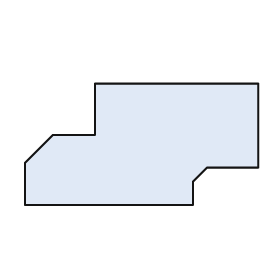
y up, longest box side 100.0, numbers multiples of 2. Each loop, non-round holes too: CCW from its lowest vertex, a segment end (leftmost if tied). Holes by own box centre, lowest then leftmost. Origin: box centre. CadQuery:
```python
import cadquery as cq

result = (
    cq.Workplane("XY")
    .moveTo(-50.0, -26.0)
    .lineTo(22.0, -26.0)
    .lineTo(22.0, -16.0)
    .lineTo(28.0, -10.0)
    .lineTo(50.0, -10.0)
    .lineTo(50.0, 26.0)
    .lineTo(-20.0, 26.0)
    .lineTo(-20.0, 4.0)
    .lineTo(-38.0, 4.0)
    .lineTo(-50.0, -8.0)
    .close()
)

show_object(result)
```